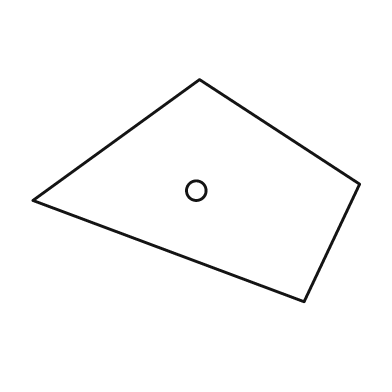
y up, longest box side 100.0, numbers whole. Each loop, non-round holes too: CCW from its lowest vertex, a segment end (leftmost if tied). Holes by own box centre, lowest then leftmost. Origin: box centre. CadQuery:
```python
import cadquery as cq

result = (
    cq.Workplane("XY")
    .moveTo(33.0, -34.0)
    .lineTo(50.0, 2.0)
    .lineTo(1.0, 34.0)
    .lineTo(-50.0, -3.0)
    .close()
    .moveTo(0.0, 0.0)
    .circle(3.0)
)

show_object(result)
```